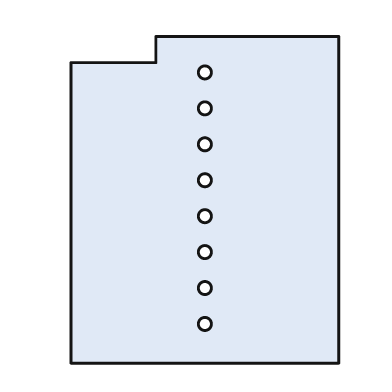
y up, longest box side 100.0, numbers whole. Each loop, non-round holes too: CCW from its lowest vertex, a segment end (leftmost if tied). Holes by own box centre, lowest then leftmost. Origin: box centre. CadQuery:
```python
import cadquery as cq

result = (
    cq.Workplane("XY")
    .moveTo(-41.0, -50.0)
    .lineTo(41.0, -50.0)
    .lineTo(41.0, 50.0)
    .lineTo(-15.0, 50.0)
    .lineTo(-15.0, 42.0)
    .lineTo(-41.0, 42.0)
    .close()
    .moveTo(0.0, -38.0)
    .circle(2.0)
    .moveTo(0.0, -27.0)
    .circle(2.0)
    .moveTo(0.0, -16.0)
    .circle(2.0)
    .moveTo(0.0, -5.0)
    .circle(2.0)
    .moveTo(0.0, 6.0)
    .circle(2.0)
    .moveTo(0.0, 17.0)
    .circle(2.0)
    .moveTo(0.0, 28.0)
    .circle(2.0)
    .moveTo(0.0, 39.0)
    .circle(2.0)
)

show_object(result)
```